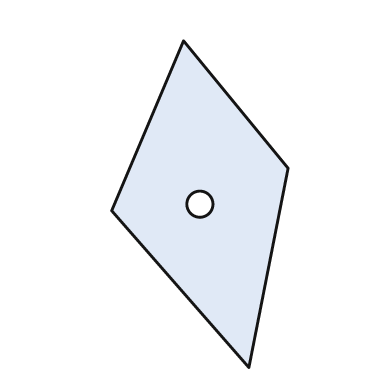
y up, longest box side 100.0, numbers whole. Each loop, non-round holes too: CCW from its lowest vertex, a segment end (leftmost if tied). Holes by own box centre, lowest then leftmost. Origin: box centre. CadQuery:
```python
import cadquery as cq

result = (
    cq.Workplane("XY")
    .moveTo(15.0, -50.0)
    .lineTo(27.0, 11.0)
    .lineTo(-5.0, 50.0)
    .lineTo(-27.0, -2.0)
    .close()
    .moveTo(0.0, 0.0)
    .circle(4.0)
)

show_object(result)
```